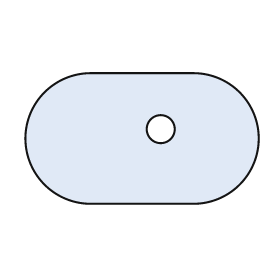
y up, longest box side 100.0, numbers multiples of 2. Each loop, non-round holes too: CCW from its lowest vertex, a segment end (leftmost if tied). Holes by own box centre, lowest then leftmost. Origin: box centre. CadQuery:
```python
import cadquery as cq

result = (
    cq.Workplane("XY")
    .moveTo(-22.0, -28.0)
    .lineTo(22.0, -28.0)
    .threePointArc((50.0, 0.0), (22.0, 28.0))
    .lineTo(-22.0, 28.0)
    .threePointArc((-50.0, 0.0), (-22.0, -28.0))
    .close()
    .moveTo(8.0, 4.0)
    .circle(6.0)
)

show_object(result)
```